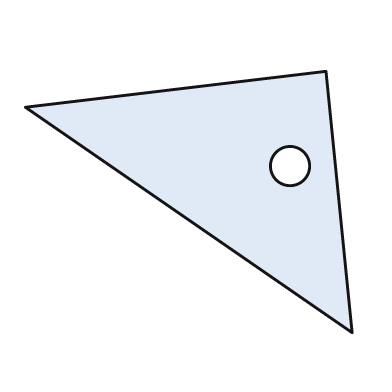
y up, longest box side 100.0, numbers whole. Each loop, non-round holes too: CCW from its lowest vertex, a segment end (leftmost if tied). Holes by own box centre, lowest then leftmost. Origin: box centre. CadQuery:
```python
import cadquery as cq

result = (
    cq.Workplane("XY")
    .moveTo(50.0, -40.0)
    .lineTo(42.0, 40.0)
    .lineTo(-50.0, 29.0)
    .close()
    .moveTo(31.0, 11.0)
    .circle(6.0)
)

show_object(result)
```